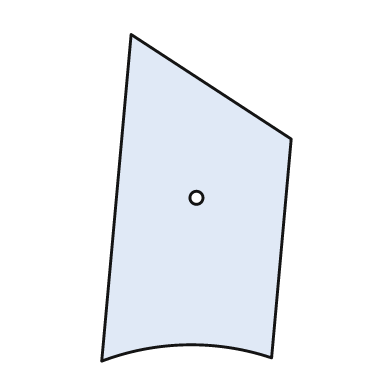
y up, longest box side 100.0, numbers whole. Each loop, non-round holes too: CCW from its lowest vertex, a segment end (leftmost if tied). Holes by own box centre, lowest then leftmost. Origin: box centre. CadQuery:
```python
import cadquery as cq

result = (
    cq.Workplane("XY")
    .moveTo(-29.0, -50.0)
    .threePointArc((-3.0, -45.0), (23.0, -49.0))
    .lineTo(29.0, 18.0)
    .lineTo(-20.0, 50.0)
    .close()
    .moveTo(0.0, 0.0)
    .circle(2.0)
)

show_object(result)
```